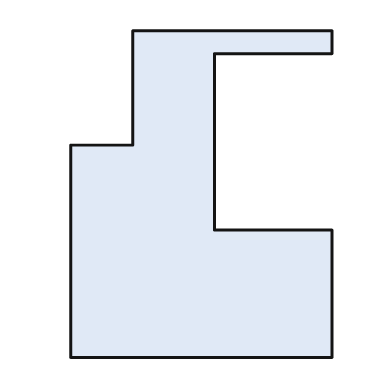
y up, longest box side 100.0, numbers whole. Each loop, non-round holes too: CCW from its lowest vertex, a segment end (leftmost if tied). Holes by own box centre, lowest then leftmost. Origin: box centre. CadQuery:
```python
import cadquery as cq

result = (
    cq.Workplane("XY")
    .moveTo(-40.0, -50.0)
    .lineTo(40.0, -50.0)
    .lineTo(40.0, -11.0)
    .lineTo(4.0, -11.0)
    .lineTo(4.0, 43.0)
    .lineTo(40.0, 43.0)
    .lineTo(40.0, 50.0)
    .lineTo(-21.0, 50.0)
    .lineTo(-21.0, 15.0)
    .lineTo(-40.0, 15.0)
    .close()
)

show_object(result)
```